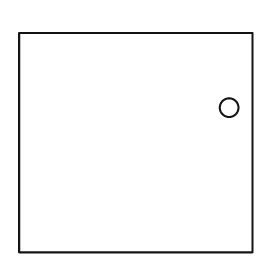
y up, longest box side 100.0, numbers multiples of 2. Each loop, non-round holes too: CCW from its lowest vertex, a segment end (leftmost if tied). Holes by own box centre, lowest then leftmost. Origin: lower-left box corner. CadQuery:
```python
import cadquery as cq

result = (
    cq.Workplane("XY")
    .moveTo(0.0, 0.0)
    .lineTo(100.0, 0.0)
    .lineTo(100.0, 94.0)
    .lineTo(0.0, 94.0)
    .close()
    .moveTo(90.0, 62.0)
    .circle(4.0)
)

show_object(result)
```